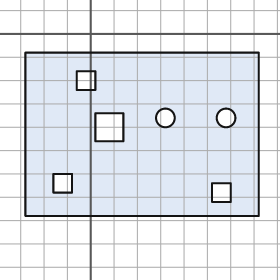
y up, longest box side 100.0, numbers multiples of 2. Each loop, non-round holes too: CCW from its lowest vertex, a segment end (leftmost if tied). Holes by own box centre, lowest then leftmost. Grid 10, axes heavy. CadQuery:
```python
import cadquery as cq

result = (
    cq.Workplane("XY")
    .moveTo(-28.0, -78.0)
    .lineTo(72.0, -78.0)
    .lineTo(72.0, -8.0)
    .lineTo(-28.0, -8.0)
    .close()
    .moveTo(52.0, -72.0)
    .lineTo(60.0, -72.0)
    .lineTo(60.0, -64.0)
    .lineTo(52.0, -64.0)
    .close()
    .moveTo(-16.0, -68.0)
    .lineTo(-8.0, -68.0)
    .lineTo(-8.0, -60.0)
    .lineTo(-16.0, -60.0)
    .close()
    .moveTo(2.0, -46.0)
    .lineTo(14.0, -46.0)
    .lineTo(14.0, -34.0)
    .lineTo(2.0, -34.0)
    .close()
    .moveTo(32.0, -36.0)
    .circle(4.0)
    .moveTo(58.0, -36.0)
    .circle(4.0)
    .moveTo(-6.0, -24.0)
    .lineTo(2.0, -24.0)
    .lineTo(2.0, -16.0)
    .lineTo(-6.0, -16.0)
    .close()
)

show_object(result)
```